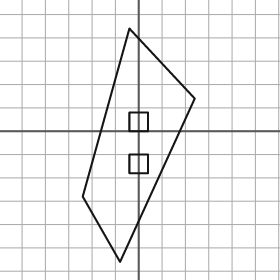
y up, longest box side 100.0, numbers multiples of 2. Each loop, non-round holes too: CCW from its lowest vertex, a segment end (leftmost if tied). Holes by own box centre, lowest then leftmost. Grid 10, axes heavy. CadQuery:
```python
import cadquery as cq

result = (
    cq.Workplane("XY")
    .moveTo(-8.0, -56.0)
    .lineTo(24.0, 14.0)
    .lineTo(-4.0, 44.0)
    .lineTo(-24.0, -28.0)
    .close()
    .moveTo(-4.0, -18.0)
    .lineTo(4.0, -18.0)
    .lineTo(4.0, -10.0)
    .lineTo(-4.0, -10.0)
    .close()
    .moveTo(-4.0, 0.0)
    .lineTo(4.0, 0.0)
    .lineTo(4.0, 8.0)
    .lineTo(-4.0, 8.0)
    .close()
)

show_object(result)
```